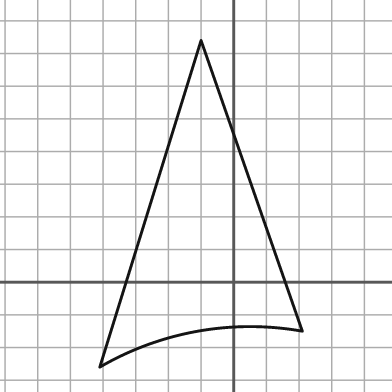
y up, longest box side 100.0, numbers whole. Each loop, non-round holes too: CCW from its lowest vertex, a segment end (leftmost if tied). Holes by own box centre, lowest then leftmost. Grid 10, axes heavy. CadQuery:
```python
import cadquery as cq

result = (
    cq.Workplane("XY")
    .moveTo(-41.0, -26.0)
    .threePointArc((-11.0, -15.0), (21.0, -15.0))
    .lineTo(-10.0, 74.0)
    .close()
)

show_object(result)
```